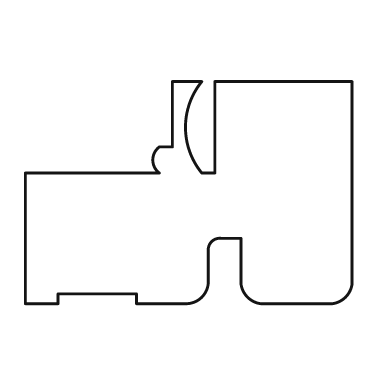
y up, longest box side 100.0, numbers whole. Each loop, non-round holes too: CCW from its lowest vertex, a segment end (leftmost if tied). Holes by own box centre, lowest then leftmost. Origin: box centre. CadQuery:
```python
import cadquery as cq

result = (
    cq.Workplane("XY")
    .moveTo(-50.0, -34.0)
    .lineTo(-40.0, -34.0)
    .lineTo(-40.0, -31.0)
    .lineTo(-16.0, -31.0)
    .lineTo(-16.0, -34.0)
    .lineTo(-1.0, -34.0)
    .threePointArc((4.0, -32.0), (6.0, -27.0))
    .lineTo(6.0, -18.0)
    .threePointArc((7.0, -15.0), (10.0, -14.0))
    .lineTo(16.0, -14.0)
    .lineTo(16.0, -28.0)
    .threePointArc((18.0, -32.0), (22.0, -34.0))
    .lineTo(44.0, -34.0)
    .threePointArc((48.0, -32.0), (50.0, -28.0))
    .lineTo(50.0, 34.0)
    .lineTo(8.0, 34.0)
    .lineTo(8.0, 6.0)
    .lineTo(4.0, 6.0)
    .threePointArc((-1.0, 20.0), (4.0, 34.0))
    .lineTo(-5.0, 34.0)
    .lineTo(-5.0, 14.0)
    .lineTo(-9.0, 14.0)
    .threePointArc((-11.0, 10.0), (-9.0, 6.0))
    .lineTo(-50.0, 6.0)
    .close()
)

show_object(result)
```